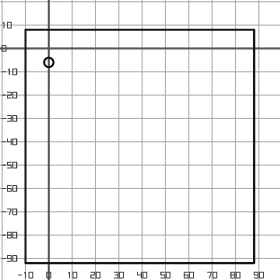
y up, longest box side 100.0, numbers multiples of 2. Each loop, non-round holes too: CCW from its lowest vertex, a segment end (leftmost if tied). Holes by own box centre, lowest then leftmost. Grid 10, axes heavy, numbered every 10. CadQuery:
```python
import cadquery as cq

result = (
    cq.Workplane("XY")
    .moveTo(-10.0, -92.0)
    .lineTo(88.0, -92.0)
    .lineTo(88.0, 8.0)
    .lineTo(-10.0, 8.0)
    .close()
    .moveTo(0.0, -6.0)
    .circle(2.0)
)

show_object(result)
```